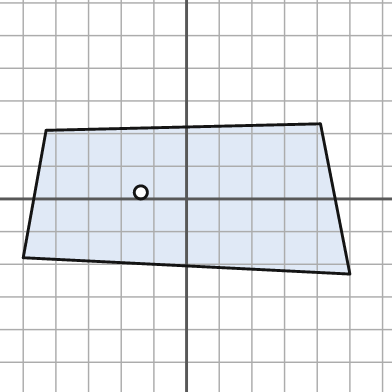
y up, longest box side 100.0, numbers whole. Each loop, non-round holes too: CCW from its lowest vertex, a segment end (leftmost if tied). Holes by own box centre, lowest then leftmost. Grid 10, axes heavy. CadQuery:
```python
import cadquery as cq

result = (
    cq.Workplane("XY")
    .moveTo(50.0, -23.0)
    .lineTo(41.0, 23.0)
    .lineTo(-43.0, 21.0)
    .lineTo(-50.0, -18.0)
    .close()
    .moveTo(-14.0, 2.0)
    .circle(2.0)
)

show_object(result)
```